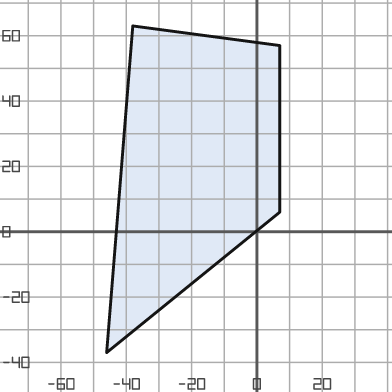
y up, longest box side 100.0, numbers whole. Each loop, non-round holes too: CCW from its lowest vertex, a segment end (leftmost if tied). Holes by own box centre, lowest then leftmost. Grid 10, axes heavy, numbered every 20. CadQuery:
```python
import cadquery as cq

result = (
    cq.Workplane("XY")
    .moveTo(-46.0, -37.0)
    .lineTo(7.0, 6.0)
    .lineTo(7.0, 57.0)
    .lineTo(-38.0, 63.0)
    .close()
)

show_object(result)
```